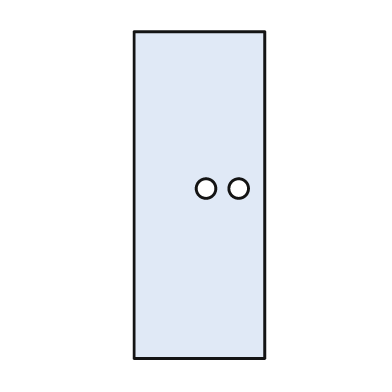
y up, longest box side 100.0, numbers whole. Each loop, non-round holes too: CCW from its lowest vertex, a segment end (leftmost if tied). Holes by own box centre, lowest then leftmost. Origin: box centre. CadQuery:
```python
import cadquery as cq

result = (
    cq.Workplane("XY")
    .moveTo(-20.0, -50.0)
    .lineTo(20.0, -50.0)
    .lineTo(20.0, 50.0)
    .lineTo(-20.0, 50.0)
    .close()
    .moveTo(2.0, 2.0)
    .circle(3.0)
    .moveTo(12.0, 2.0)
    .circle(3.0)
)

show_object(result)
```